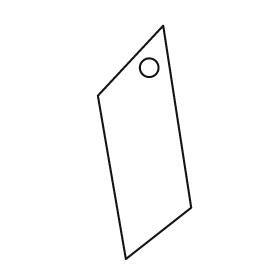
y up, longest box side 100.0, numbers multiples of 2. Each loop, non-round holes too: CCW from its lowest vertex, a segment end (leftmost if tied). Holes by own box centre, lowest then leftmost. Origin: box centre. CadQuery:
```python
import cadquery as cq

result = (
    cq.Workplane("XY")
    .moveTo(-8.0, -50.0)
    .lineTo(20.0, -28.0)
    .lineTo(8.0, 50.0)
    .lineTo(-20.0, 20.0)
    .close()
    .moveTo(2.0, 32.0)
    .circle(4.0)
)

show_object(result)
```